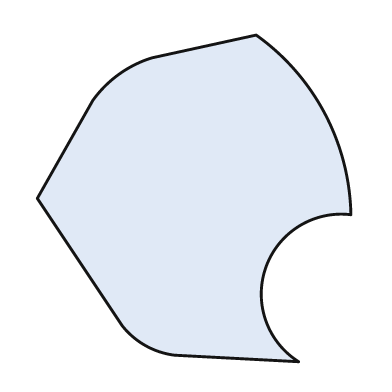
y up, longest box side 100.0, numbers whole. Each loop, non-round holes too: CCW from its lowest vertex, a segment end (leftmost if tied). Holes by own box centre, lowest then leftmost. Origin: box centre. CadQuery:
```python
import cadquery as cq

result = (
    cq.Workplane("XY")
    .moveTo(32.0, -50.0)
    .threePointArc((22.0, -21.0), (48.0, -5.0))
    .threePointArc((40.0, 26.0), (19.0, 50.0))
    .lineTo(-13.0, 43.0)
    .threePointArc((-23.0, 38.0), (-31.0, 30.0))
    .lineTo(-48.0, 0.0)
    .lineTo(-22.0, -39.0)
    .threePointArc((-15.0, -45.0), (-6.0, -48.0))
    .close()
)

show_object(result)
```